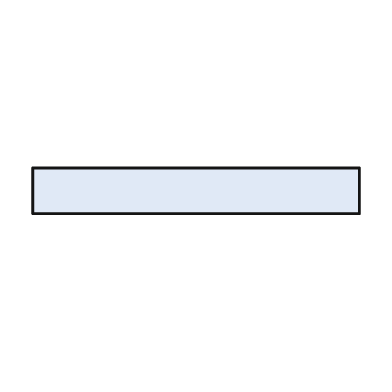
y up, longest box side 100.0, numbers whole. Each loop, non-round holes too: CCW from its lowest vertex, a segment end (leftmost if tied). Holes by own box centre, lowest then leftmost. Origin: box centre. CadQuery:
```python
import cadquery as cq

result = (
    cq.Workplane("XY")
    .moveTo(-50.0, -7.0)
    .lineTo(50.0, -7.0)
    .lineTo(50.0, 7.0)
    .lineTo(-50.0, 7.0)
    .close()
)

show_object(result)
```